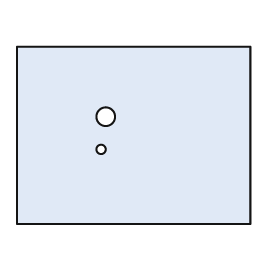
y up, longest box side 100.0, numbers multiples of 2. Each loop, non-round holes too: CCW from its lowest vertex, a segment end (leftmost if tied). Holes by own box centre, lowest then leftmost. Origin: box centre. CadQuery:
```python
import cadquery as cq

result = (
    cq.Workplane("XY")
    .moveTo(-50.0, -38.0)
    .lineTo(50.0, -38.0)
    .lineTo(50.0, 38.0)
    .lineTo(-50.0, 38.0)
    .close()
    .moveTo(-14.0, -6.0)
    .circle(2.0)
    .moveTo(-12.0, 8.0)
    .circle(4.0)
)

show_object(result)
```